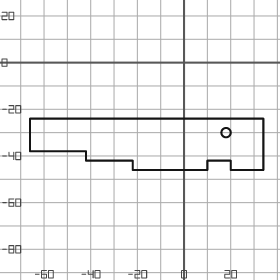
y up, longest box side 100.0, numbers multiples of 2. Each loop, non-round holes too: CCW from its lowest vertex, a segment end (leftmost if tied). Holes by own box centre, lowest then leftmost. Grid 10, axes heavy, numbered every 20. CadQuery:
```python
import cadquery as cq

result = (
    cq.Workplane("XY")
    .moveTo(-22.0, -46.0)
    .lineTo(10.0, -46.0)
    .lineTo(10.0, -42.0)
    .lineTo(20.0, -42.0)
    .lineTo(20.0, -46.0)
    .lineTo(34.0, -46.0)
    .lineTo(34.0, -24.0)
    .lineTo(-66.0, -24.0)
    .lineTo(-66.0, -38.0)
    .lineTo(-42.0, -38.0)
    .lineTo(-42.0, -42.0)
    .lineTo(-22.0, -42.0)
    .close()
    .moveTo(18.0, -30.0)
    .circle(2.0)
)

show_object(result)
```